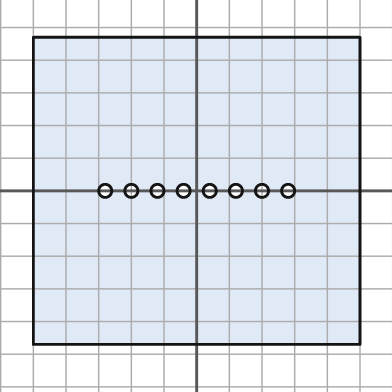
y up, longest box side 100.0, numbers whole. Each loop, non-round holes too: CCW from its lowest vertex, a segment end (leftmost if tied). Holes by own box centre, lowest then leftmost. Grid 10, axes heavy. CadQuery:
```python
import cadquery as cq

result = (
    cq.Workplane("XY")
    .moveTo(-50.0, -47.0)
    .lineTo(50.0, -47.0)
    .lineTo(50.0, 47.0)
    .lineTo(-50.0, 47.0)
    .close()
    .moveTo(-28.0, 0.0)
    .circle(2.0)
    .moveTo(-20.0, 0.0)
    .circle(2.0)
    .moveTo(-12.0, 0.0)
    .circle(2.0)
    .moveTo(-4.0, 0.0)
    .circle(2.0)
    .moveTo(4.0, 0.0)
    .circle(2.0)
    .moveTo(12.0, 0.0)
    .circle(2.0)
    .moveTo(20.0, 0.0)
    .circle(2.0)
    .moveTo(28.0, 0.0)
    .circle(2.0)
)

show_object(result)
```